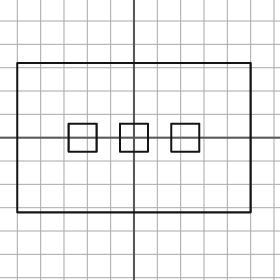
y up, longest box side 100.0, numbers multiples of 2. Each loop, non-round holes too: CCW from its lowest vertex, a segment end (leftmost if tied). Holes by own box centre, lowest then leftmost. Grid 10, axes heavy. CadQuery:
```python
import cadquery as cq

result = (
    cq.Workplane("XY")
    .moveTo(-50.0, -32.0)
    .lineTo(50.0, -32.0)
    .lineTo(50.0, 32.0)
    .lineTo(-50.0, 32.0)
    .close()
    .moveTo(-28.0, -6.0)
    .lineTo(-16.0, -6.0)
    .lineTo(-16.0, 6.0)
    .lineTo(-28.0, 6.0)
    .close()
    .moveTo(-6.0, -6.0)
    .lineTo(6.0, -6.0)
    .lineTo(6.0, 6.0)
    .lineTo(-6.0, 6.0)
    .close()
    .moveTo(16.0, -6.0)
    .lineTo(28.0, -6.0)
    .lineTo(28.0, 6.0)
    .lineTo(16.0, 6.0)
    .close()
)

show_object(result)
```